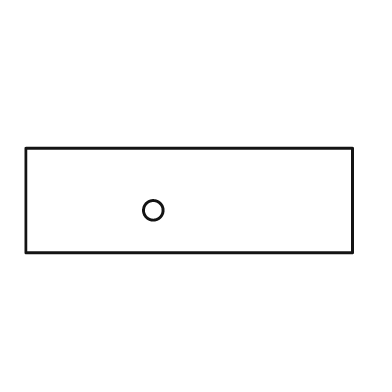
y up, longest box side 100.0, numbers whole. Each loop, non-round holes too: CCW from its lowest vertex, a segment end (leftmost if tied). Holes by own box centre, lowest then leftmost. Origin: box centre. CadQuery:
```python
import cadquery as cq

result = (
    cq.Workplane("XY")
    .moveTo(-50.0, -16.0)
    .lineTo(50.0, -16.0)
    .lineTo(50.0, 16.0)
    .lineTo(-50.0, 16.0)
    .close()
    .moveTo(-11.0, -3.0)
    .circle(3.0)
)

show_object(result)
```